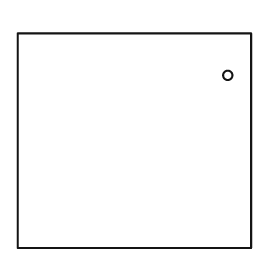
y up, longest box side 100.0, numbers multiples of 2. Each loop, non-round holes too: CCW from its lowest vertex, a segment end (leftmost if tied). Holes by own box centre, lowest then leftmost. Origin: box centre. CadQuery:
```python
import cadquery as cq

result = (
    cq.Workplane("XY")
    .moveTo(-50.0, -46.0)
    .lineTo(50.0, -46.0)
    .lineTo(50.0, 46.0)
    .lineTo(-50.0, 46.0)
    .close()
    .moveTo(40.0, 28.0)
    .circle(2.0)
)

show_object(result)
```